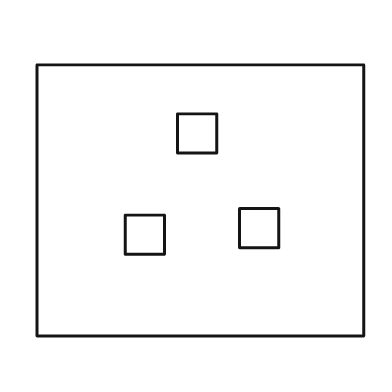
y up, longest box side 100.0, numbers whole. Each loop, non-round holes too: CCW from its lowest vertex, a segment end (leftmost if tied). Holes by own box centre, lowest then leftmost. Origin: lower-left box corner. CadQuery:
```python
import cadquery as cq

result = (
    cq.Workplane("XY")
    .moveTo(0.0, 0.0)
    .lineTo(100.0, 0.0)
    .lineTo(100.0, 83.0)
    .lineTo(0.0, 83.0)
    .close()
    .moveTo(27.0, 25.0)
    .lineTo(39.0, 25.0)
    .lineTo(39.0, 37.0)
    .lineTo(27.0, 37.0)
    .close()
    .moveTo(62.0, 27.0)
    .lineTo(74.0, 27.0)
    .lineTo(74.0, 39.0)
    .lineTo(62.0, 39.0)
    .close()
    .moveTo(43.0, 56.0)
    .lineTo(55.0, 56.0)
    .lineTo(55.0, 68.0)
    .lineTo(43.0, 68.0)
    .close()
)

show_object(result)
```